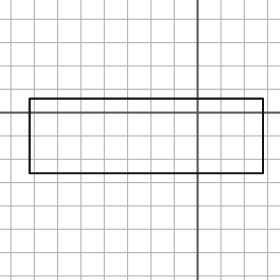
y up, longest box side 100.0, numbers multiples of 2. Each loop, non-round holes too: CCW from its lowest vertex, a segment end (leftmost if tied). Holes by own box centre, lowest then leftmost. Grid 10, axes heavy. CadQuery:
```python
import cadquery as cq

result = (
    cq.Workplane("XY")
    .moveTo(-72.0, -26.0)
    .lineTo(28.0, -26.0)
    .lineTo(28.0, 6.0)
    .lineTo(-72.0, 6.0)
    .close()
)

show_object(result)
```